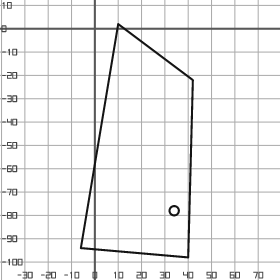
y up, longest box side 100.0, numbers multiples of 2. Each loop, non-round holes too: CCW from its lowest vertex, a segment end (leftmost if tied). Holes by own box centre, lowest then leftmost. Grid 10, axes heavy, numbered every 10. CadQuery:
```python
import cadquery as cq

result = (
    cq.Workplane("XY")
    .moveTo(40.0, -98.0)
    .lineTo(42.0, -22.0)
    .lineTo(10.0, 2.0)
    .lineTo(-6.0, -94.0)
    .close()
    .moveTo(34.0, -78.0)
    .circle(2.0)
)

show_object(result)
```